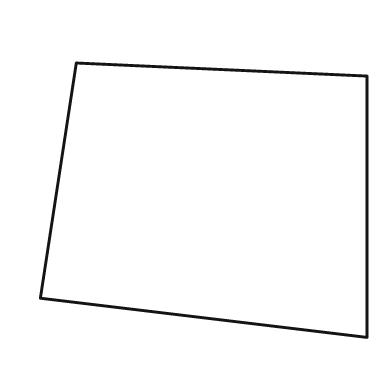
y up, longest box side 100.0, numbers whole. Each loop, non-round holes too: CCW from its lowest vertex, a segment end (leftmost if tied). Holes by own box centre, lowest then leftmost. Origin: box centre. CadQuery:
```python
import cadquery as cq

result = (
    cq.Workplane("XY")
    .moveTo(50.0, -42.0)
    .lineTo(50.0, 38.0)
    .lineTo(-39.0, 42.0)
    .lineTo(-50.0, -30.0)
    .close()
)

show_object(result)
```